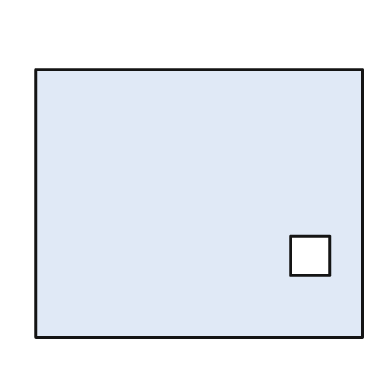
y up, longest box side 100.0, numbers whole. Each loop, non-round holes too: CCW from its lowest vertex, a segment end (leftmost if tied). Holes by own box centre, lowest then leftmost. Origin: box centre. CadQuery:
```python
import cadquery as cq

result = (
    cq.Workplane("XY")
    .moveTo(-50.0, -41.0)
    .lineTo(50.0, -41.0)
    .lineTo(50.0, 41.0)
    .lineTo(-50.0, 41.0)
    .close()
    .moveTo(28.0, -22.0)
    .lineTo(40.0, -22.0)
    .lineTo(40.0, -10.0)
    .lineTo(28.0, -10.0)
    .close()
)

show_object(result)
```